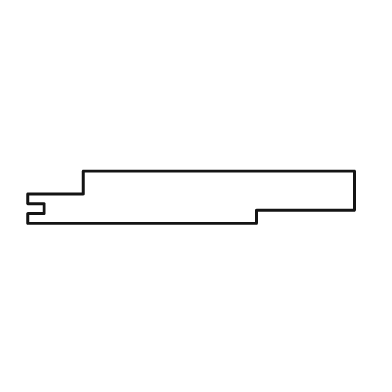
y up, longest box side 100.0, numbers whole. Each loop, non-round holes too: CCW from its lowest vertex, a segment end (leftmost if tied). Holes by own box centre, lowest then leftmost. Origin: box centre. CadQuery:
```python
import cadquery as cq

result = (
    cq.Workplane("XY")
    .moveTo(-50.0, -8.0)
    .lineTo(20.0, -8.0)
    .lineTo(20.0, -4.0)
    .lineTo(50.0, -4.0)
    .lineTo(50.0, 8.0)
    .lineTo(-33.0, 8.0)
    .lineTo(-33.0, 1.0)
    .lineTo(-50.0, 1.0)
    .lineTo(-50.0, -2.0)
    .lineTo(-45.0, -2.0)
    .lineTo(-45.0, -5.0)
    .lineTo(-50.0, -5.0)
    .close()
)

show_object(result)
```